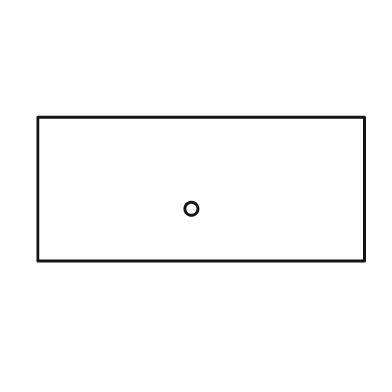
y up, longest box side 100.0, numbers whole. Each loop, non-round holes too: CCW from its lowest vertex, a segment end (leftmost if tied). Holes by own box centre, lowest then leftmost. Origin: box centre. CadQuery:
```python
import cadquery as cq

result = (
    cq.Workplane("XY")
    .moveTo(-50.0, -22.0)
    .lineTo(50.0, -22.0)
    .lineTo(50.0, 22.0)
    .lineTo(-50.0, 22.0)
    .close()
    .moveTo(-3.0, -6.0)
    .circle(2.0)
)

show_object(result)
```